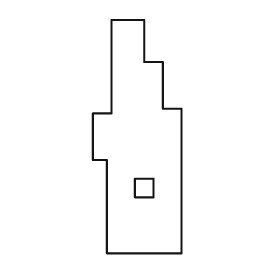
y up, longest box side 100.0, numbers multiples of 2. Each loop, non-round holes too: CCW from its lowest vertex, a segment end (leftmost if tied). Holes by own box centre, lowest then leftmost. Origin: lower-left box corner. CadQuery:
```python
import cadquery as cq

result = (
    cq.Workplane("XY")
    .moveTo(6.0, 0.0)
    .lineTo(38.0, 0.0)
    .lineTo(38.0, 62.0)
    .lineTo(30.0, 62.0)
    .lineTo(30.0, 82.0)
    .lineTo(22.0, 82.0)
    .lineTo(22.0, 100.0)
    .lineTo(8.0, 100.0)
    .lineTo(8.0, 60.0)
    .lineTo(0.0, 60.0)
    .lineTo(0.0, 40.0)
    .lineTo(6.0, 40.0)
    .close()
    .moveTo(18.0, 24.0)
    .lineTo(26.0, 24.0)
    .lineTo(26.0, 32.0)
    .lineTo(18.0, 32.0)
    .close()
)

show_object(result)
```